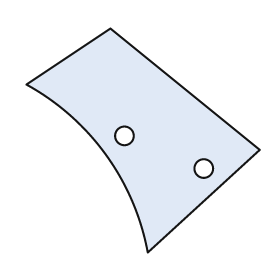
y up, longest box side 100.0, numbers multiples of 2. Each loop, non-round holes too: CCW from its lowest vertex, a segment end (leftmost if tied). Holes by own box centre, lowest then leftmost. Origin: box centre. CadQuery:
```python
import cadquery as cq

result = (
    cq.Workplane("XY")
    .moveTo(2.0, -48.0)
    .lineTo(50.0, -4.0)
    .lineTo(-14.0, 48.0)
    .lineTo(-50.0, 24.0)
    .threePointArc((-16.0, -6.0), (2.0, -48.0))
    .close()
    .moveTo(26.0, -12.0)
    .circle(4.0)
    .moveTo(-8.0, 2.0)
    .circle(4.0)
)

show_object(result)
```